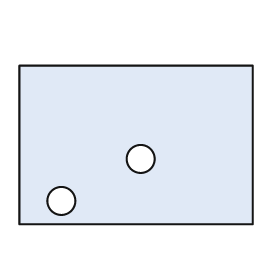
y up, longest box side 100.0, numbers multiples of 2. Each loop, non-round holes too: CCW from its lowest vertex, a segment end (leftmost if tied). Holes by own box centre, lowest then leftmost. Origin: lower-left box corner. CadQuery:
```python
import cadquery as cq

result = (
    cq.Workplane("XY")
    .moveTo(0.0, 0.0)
    .lineTo(100.0, 0.0)
    .lineTo(100.0, 68.0)
    .lineTo(0.0, 68.0)
    .close()
    .moveTo(18.0, 10.0)
    .circle(6.0)
    .moveTo(52.0, 28.0)
    .circle(6.0)
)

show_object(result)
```